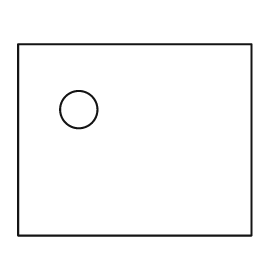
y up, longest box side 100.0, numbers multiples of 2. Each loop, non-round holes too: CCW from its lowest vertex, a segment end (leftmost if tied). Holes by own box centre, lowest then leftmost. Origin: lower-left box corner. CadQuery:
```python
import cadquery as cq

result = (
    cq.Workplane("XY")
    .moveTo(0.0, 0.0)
    .lineTo(100.0, 0.0)
    .lineTo(100.0, 82.0)
    .lineTo(0.0, 82.0)
    .close()
    .moveTo(26.0, 54.0)
    .circle(8.0)
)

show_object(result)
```